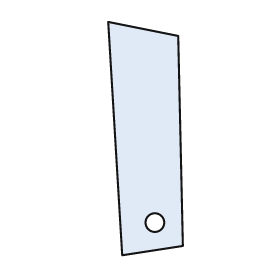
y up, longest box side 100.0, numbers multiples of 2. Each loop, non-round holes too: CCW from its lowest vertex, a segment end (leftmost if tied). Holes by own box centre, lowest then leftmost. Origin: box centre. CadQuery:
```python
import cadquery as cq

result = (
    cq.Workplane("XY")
    .moveTo(-10.0, -50.0)
    .lineTo(16.0, -46.0)
    .lineTo(14.0, 44.0)
    .lineTo(-16.0, 50.0)
    .close()
    .moveTo(4.0, -36.0)
    .circle(4.0)
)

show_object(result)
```